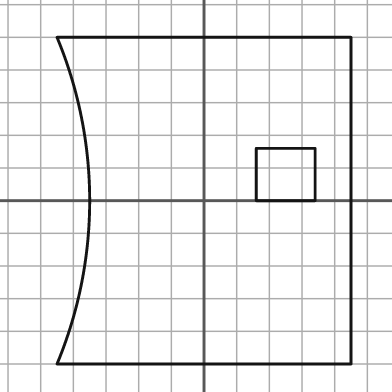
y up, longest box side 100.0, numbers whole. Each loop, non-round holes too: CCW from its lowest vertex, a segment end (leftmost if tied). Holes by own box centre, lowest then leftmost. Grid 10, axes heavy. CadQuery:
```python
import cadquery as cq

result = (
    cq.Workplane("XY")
    .moveTo(-45.0, -50.0)
    .lineTo(45.0, -50.0)
    .lineTo(45.0, 50.0)
    .lineTo(-45.0, 50.0)
    .threePointArc((-35.0, 0.0), (-45.0, -50.0))
    .close()
    .moveTo(16.0, 0.0)
    .lineTo(34.0, 0.0)
    .lineTo(34.0, 16.0)
    .lineTo(16.0, 16.0)
    .close()
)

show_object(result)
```